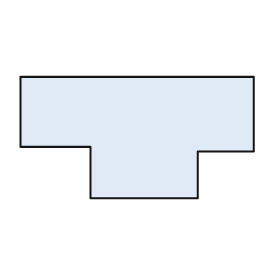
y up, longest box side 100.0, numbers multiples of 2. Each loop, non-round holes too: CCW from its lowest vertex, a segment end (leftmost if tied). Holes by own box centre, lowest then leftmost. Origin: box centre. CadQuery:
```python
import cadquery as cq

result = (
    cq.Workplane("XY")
    .moveTo(-20.0, -26.0)
    .lineTo(26.0, -26.0)
    .lineTo(26.0, -6.0)
    .lineTo(50.0, -6.0)
    .lineTo(50.0, 26.0)
    .lineTo(-50.0, 26.0)
    .lineTo(-50.0, -4.0)
    .lineTo(-20.0, -4.0)
    .close()
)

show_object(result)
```